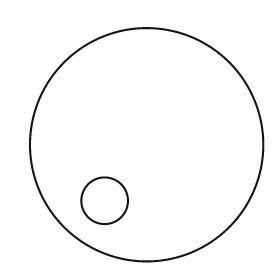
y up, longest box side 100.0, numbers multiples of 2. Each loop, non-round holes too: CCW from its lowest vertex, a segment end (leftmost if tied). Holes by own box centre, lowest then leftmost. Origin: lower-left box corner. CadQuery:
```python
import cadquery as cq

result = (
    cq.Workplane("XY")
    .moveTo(50.0, 50.0)
    .circle(50.0)
    .moveTo(32.0, 26.0)
    .circle(10.0)
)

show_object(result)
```